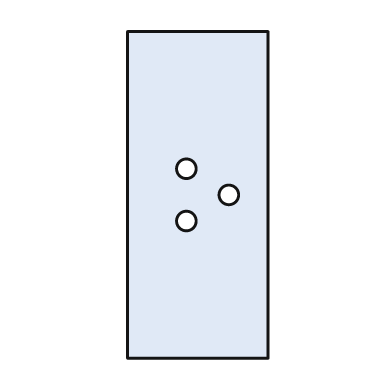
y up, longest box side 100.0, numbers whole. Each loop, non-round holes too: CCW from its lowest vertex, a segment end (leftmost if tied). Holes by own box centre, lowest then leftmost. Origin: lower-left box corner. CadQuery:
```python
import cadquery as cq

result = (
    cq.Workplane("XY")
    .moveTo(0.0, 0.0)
    .lineTo(43.0, 0.0)
    .lineTo(43.0, 100.0)
    .lineTo(0.0, 100.0)
    .close()
    .moveTo(18.0, 42.0)
    .circle(3.0)
    .moveTo(31.0, 50.0)
    .circle(3.0)
    .moveTo(18.0, 58.0)
    .circle(3.0)
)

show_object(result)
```